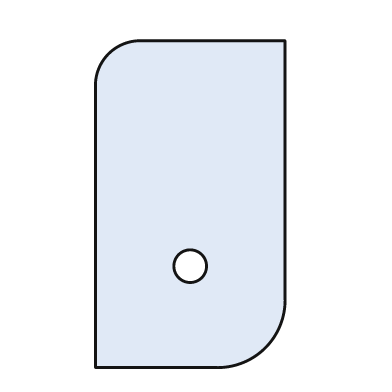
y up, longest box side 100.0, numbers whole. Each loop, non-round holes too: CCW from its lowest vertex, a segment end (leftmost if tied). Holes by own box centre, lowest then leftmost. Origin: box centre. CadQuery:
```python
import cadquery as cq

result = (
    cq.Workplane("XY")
    .moveTo(-29.0, -50.0)
    .lineTo(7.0, -50.0)
    .threePointArc((23.0, -44.0), (29.0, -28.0))
    .lineTo(29.0, 50.0)
    .lineTo(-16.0, 50.0)
    .threePointArc((-25.0, 46.0), (-29.0, 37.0))
    .close()
    .moveTo(0.0, -19.0)
    .circle(5.0)
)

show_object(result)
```